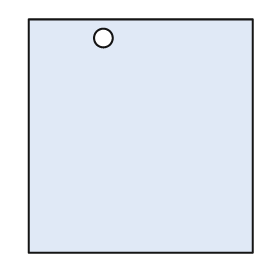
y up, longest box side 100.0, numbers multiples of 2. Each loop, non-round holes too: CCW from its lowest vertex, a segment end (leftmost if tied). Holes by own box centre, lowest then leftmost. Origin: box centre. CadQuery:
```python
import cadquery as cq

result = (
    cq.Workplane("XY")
    .moveTo(-48.0, -50.0)
    .lineTo(48.0, -50.0)
    .lineTo(48.0, 50.0)
    .lineTo(-48.0, 50.0)
    .close()
    .moveTo(-16.0, 42.0)
    .circle(4.0)
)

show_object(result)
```